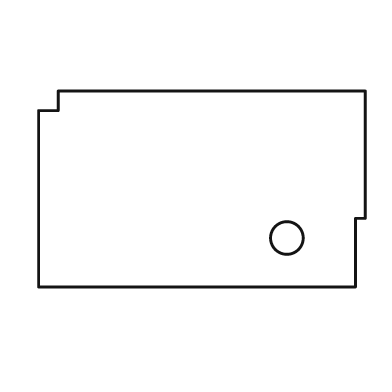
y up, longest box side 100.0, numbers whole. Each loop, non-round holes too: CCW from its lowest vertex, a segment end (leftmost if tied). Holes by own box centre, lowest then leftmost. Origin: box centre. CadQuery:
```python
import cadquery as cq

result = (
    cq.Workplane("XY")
    .moveTo(-50.0, -30.0)
    .lineTo(47.0, -30.0)
    .lineTo(47.0, -9.0)
    .lineTo(50.0, -9.0)
    .lineTo(50.0, 30.0)
    .lineTo(-44.0, 30.0)
    .lineTo(-44.0, 24.0)
    .lineTo(-50.0, 24.0)
    .close()
    .moveTo(26.0, -15.0)
    .circle(5.0)
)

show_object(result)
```